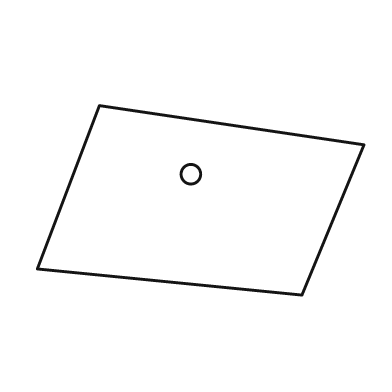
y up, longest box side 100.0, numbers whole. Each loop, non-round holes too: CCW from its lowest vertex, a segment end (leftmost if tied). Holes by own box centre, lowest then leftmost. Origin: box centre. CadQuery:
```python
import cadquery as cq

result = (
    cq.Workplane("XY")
    .moveTo(31.0, -29.0)
    .lineTo(50.0, 17.0)
    .lineTo(-31.0, 29.0)
    .lineTo(-50.0, -21.0)
    .close()
    .moveTo(-3.0, 8.0)
    .circle(3.0)
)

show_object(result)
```